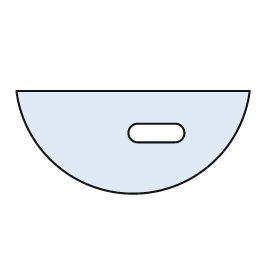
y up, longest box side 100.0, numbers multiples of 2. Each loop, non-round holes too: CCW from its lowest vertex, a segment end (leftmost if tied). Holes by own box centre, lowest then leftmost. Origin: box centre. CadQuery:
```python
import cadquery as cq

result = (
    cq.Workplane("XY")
    .moveTo(-50.0, 22.0)
    .threePointArc((0.0, -22.0), (50.0, 22.0))
    .close()
    .moveTo(2.0, 0.0)
    .lineTo(18.0, 0.0)
    .threePointArc((22.0, 4.0), (18.0, 8.0))
    .lineTo(2.0, 8.0)
    .threePointArc((-2.0, 4.0), (2.0, 0.0))
    .close()
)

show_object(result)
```